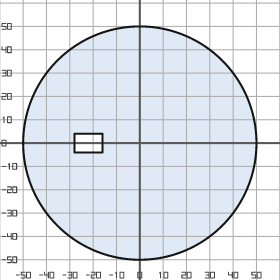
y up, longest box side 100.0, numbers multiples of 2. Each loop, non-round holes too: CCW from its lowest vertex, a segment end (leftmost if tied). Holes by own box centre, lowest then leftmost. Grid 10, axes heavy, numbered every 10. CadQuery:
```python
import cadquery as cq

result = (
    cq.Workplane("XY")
    .moveTo(0.0, 0.0)
    .circle(50.0)
    .moveTo(-28.0, -4.0)
    .lineTo(-16.0, -4.0)
    .lineTo(-16.0, 4.0)
    .lineTo(-28.0, 4.0)
    .close()
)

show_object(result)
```